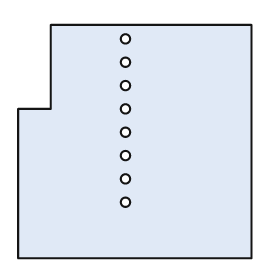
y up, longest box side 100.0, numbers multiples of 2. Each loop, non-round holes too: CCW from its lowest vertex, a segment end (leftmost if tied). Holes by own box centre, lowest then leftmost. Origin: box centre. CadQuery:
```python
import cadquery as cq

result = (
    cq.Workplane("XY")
    .moveTo(-50.0, -50.0)
    .lineTo(50.0, -50.0)
    .lineTo(50.0, 50.0)
    .lineTo(-36.0, 50.0)
    .lineTo(-36.0, 14.0)
    .lineTo(-50.0, 14.0)
    .close()
    .moveTo(-4.0, -26.0)
    .circle(2.0)
    .moveTo(-4.0, -16.0)
    .circle(2.0)
    .moveTo(-4.0, -6.0)
    .circle(2.0)
    .moveTo(-4.0, 4.0)
    .circle(2.0)
    .moveTo(-4.0, 14.0)
    .circle(2.0)
    .moveTo(-4.0, 24.0)
    .circle(2.0)
    .moveTo(-4.0, 34.0)
    .circle(2.0)
    .moveTo(-4.0, 44.0)
    .circle(2.0)
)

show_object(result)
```